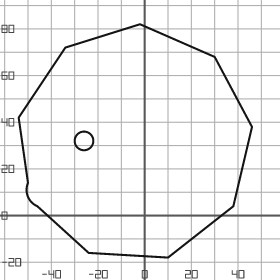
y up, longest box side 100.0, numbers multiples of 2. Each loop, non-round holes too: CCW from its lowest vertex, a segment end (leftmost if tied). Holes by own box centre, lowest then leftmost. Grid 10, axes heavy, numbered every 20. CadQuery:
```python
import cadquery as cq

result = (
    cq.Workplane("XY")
    .moveTo(10.0, -18.0)
    .lineTo(38.0, 4.0)
    .lineTo(46.0, 38.0)
    .lineTo(30.0, 68.0)
    .lineTo(-2.0, 82.0)
    .lineTo(-34.0, 72.0)
    .lineTo(-54.0, 42.0)
    .lineTo(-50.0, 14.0)
    .threePointArc((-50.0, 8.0), (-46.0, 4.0))
    .lineTo(-24.0, -16.0)
    .close()
    .moveTo(-26.0, 32.0)
    .circle(4.0)
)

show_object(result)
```